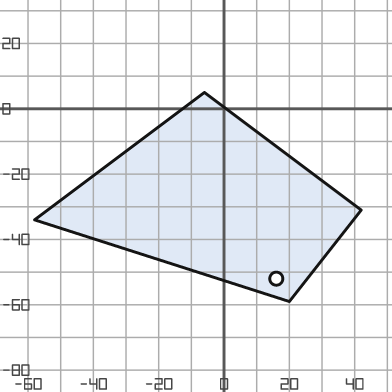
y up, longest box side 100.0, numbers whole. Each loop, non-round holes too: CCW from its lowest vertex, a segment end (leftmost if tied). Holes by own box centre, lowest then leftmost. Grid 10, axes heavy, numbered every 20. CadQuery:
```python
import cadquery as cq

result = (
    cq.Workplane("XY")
    .moveTo(20.0, -59.0)
    .lineTo(42.0, -31.0)
    .lineTo(-6.0, 5.0)
    .lineTo(-58.0, -34.0)
    .close()
    .moveTo(16.0, -52.0)
    .circle(2.0)
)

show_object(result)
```